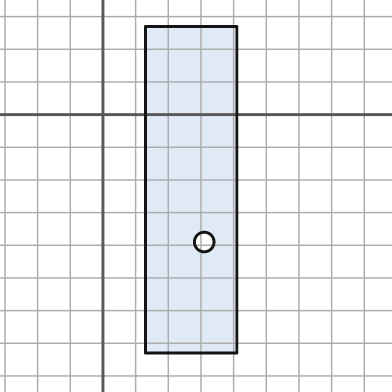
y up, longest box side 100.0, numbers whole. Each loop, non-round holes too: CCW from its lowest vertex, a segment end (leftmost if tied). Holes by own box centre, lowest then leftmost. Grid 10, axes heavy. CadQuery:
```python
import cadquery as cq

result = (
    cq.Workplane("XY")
    .moveTo(13.0, -73.0)
    .lineTo(41.0, -73.0)
    .lineTo(41.0, 27.0)
    .lineTo(13.0, 27.0)
    .close()
    .moveTo(31.0, -39.0)
    .circle(3.0)
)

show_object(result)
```